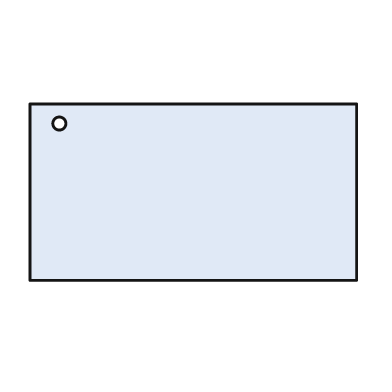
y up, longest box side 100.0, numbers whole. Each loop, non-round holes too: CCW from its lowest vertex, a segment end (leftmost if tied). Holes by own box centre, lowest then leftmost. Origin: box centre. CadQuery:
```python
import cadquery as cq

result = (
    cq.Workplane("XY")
    .moveTo(-50.0, -27.0)
    .lineTo(50.0, -27.0)
    .lineTo(50.0, 27.0)
    .lineTo(-50.0, 27.0)
    .close()
    .moveTo(-41.0, 21.0)
    .circle(2.0)
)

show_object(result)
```